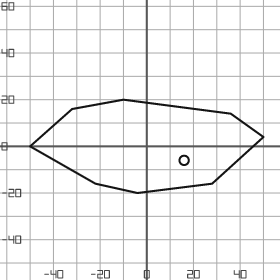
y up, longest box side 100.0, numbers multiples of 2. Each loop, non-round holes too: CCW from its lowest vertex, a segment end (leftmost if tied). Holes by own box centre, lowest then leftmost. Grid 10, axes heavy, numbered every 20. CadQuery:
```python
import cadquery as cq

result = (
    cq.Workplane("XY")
    .moveTo(-4.0, -20.0)
    .lineTo(28.0, -16.0)
    .lineTo(50.0, 4.0)
    .lineTo(36.0, 14.0)
    .lineTo(-10.0, 20.0)
    .lineTo(-32.0, 16.0)
    .lineTo(-50.0, 0.0)
    .lineTo(-22.0, -16.0)
    .close()
    .moveTo(16.0, -6.0)
    .circle(2.0)
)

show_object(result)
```